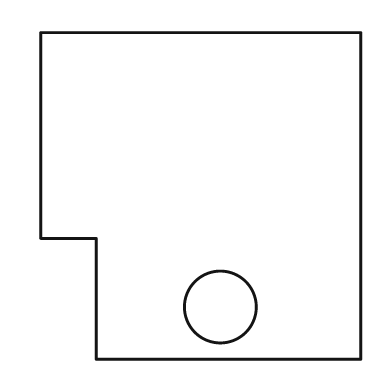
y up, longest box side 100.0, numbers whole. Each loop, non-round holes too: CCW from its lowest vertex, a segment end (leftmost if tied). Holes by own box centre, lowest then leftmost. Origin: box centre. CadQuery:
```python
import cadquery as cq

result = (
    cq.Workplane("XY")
    .moveTo(-32.0, -50.0)
    .lineTo(49.0, -50.0)
    .lineTo(49.0, 50.0)
    .lineTo(-49.0, 50.0)
    .lineTo(-49.0, -13.0)
    .lineTo(-32.0, -13.0)
    .close()
    .moveTo(6.0, -34.0)
    .circle(11.0)
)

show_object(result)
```